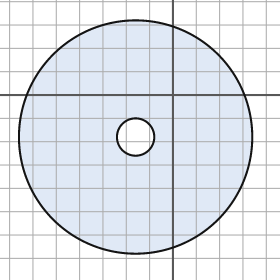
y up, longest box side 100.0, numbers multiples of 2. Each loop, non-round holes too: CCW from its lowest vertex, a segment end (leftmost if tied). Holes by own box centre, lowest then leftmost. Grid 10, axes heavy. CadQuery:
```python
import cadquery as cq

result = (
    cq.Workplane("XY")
    .moveTo(-16.0, -18.0)
    .circle(50.0)
    .moveTo(-16.0, -18.0)
    .circle(8.0)
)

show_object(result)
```